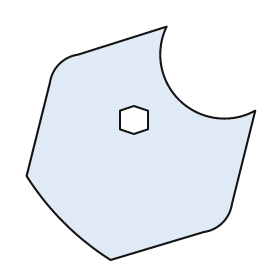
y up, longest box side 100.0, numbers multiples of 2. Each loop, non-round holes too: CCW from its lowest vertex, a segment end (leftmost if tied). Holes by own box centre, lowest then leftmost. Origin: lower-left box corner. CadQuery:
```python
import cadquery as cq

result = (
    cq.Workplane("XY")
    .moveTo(36.0, 0.0)
    .lineTo(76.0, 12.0)
    .threePointArc((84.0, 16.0), (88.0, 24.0))
    .lineTo(98.0, 64.0)
    .threePointArc((66.0, 68.0), (60.0, 100.0))
    .lineTo(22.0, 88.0)
    .threePointArc((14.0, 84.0), (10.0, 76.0))
    .lineTo(0.0, 36.0)
    .threePointArc((16.0, 16.0), (36.0, 0.0))
    .close()
    .moveTo(46.0, 54.0)
    .lineTo(52.0, 56.0)
    .lineTo(52.0, 64.0)
    .lineTo(46.0, 66.0)
    .lineTo(40.0, 64.0)
    .lineTo(40.0, 56.0)
    .close()
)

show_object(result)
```